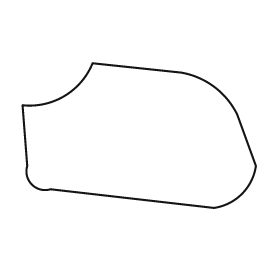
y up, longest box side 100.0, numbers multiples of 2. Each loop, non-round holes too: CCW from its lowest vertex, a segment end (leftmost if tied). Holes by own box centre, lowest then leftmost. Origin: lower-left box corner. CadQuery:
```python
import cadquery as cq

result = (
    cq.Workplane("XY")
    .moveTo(82.0, 0.0)
    .threePointArc((94.0, 6.0), (100.0, 18.0))
    .lineTo(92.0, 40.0)
    .threePointArc((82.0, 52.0), (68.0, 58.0))
    .lineTo(30.0, 62.0)
    .threePointArc((18.0, 48.0), (0.0, 44.0))
    .lineTo(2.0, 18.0)
    .threePointArc((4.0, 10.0), (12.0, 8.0))
    .close()
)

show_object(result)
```